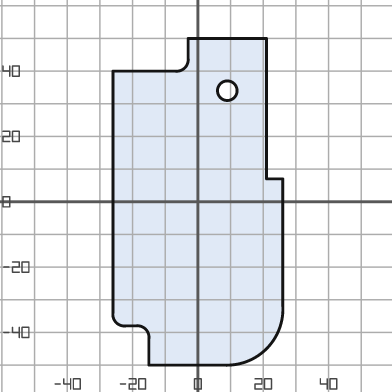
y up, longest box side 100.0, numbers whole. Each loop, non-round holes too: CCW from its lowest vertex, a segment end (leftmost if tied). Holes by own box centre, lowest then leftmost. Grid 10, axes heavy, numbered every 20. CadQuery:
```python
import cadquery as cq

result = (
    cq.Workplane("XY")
    .moveTo(-15.0, -50.0)
    .lineTo(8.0, -50.0)
    .threePointArc((21.0, -45.0), (26.0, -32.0))
    .lineTo(26.0, 7.0)
    .lineTo(21.0, 7.0)
    .lineTo(21.0, 50.0)
    .lineTo(-3.0, 50.0)
    .lineTo(-3.0, 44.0)
    .threePointArc((-4.0, 41.0), (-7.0, 40.0))
    .lineTo(-26.0, 40.0)
    .lineTo(-26.0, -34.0)
    .threePointArc((-25.0, -37.0), (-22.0, -38.0))
    .lineTo(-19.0, -38.0)
    .threePointArc((-16.0, -39.0), (-15.0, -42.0))
    .close()
    .moveTo(9.0, 34.0)
    .circle(3.0)
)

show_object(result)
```